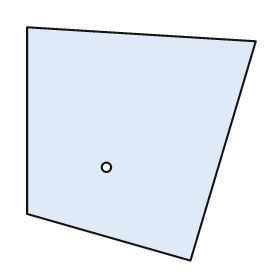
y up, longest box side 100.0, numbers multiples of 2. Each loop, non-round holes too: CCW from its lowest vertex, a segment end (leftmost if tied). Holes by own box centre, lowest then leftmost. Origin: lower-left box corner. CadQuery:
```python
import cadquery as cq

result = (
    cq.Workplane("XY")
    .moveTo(70.0, 0.0)
    .lineTo(98.0, 94.0)
    .lineTo(0.0, 100.0)
    .lineTo(0.0, 20.0)
    .close()
    .moveTo(34.0, 40.0)
    .circle(2.0)
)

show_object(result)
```